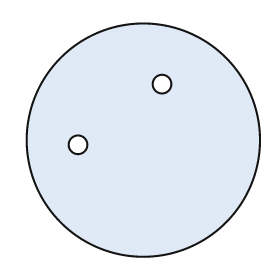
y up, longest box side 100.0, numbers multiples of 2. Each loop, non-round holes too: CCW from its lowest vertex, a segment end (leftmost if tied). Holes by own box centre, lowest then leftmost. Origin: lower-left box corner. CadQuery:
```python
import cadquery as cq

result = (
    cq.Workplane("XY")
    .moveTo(50.0, 50.0)
    .circle(50.0)
    .moveTo(22.0, 48.0)
    .circle(4.0)
    .moveTo(58.0, 74.0)
    .circle(4.0)
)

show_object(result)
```